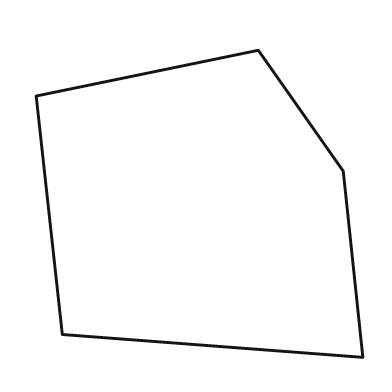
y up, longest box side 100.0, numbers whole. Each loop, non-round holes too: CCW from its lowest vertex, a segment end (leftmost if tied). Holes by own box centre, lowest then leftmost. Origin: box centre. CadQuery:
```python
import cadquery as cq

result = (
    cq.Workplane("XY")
    .moveTo(50.0, -47.0)
    .lineTo(44.0, 10.0)
    .lineTo(18.0, 47.0)
    .lineTo(-50.0, 33.0)
    .lineTo(-42.0, -40.0)
    .close()
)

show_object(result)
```